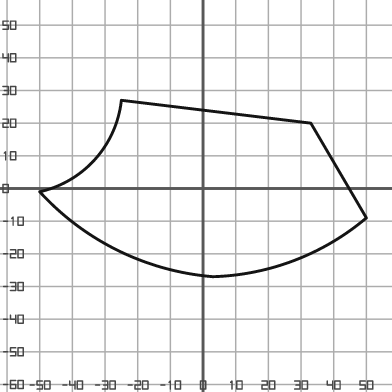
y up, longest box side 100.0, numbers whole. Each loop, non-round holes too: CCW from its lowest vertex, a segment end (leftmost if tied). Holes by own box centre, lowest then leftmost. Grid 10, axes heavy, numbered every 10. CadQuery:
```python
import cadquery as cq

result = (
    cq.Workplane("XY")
    .moveTo(3.0, -27.0)
    .threePointArc((28.0, -22.0), (50.0, -9.0))
    .lineTo(33.0, 20.0)
    .lineTo(-25.0, 27.0)
    .threePointArc((-33.0, 9.0), (-50.0, -1.0))
    .threePointArc((-26.0, -19.0), (3.0, -27.0))
    .close()
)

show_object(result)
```